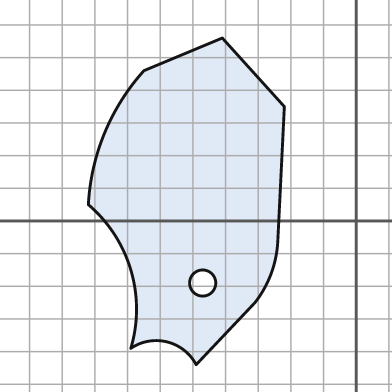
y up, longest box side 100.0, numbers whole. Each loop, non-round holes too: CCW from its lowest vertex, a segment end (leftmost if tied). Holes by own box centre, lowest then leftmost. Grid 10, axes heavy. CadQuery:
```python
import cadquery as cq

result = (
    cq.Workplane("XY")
    .moveTo(-49.0, -44.0)
    .lineTo(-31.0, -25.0)
    .threePointArc((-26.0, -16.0), (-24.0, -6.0))
    .lineTo(-22.0, 35.0)
    .lineTo(-41.0, 56.0)
    .lineTo(-65.0, 46.0)
    .threePointArc((-77.0, 27.0), (-82.0, 5.0))
    .threePointArc((-69.0, -15.0), (-69.0, -39.0))
    .threePointArc((-58.0, -37.0), (-49.0, -44.0))
    .close()
    .moveTo(-47.0, -19.0)
    .circle(4.0)
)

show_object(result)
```